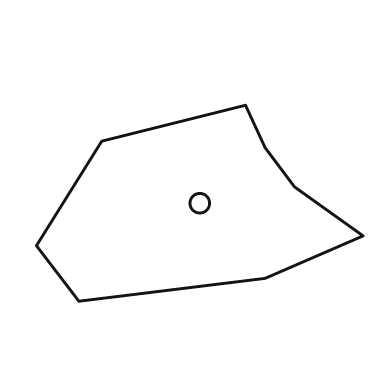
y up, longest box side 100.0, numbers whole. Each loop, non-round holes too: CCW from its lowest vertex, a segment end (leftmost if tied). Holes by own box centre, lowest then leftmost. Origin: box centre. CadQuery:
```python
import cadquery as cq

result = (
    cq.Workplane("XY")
    .moveTo(-37.0, -30.0)
    .lineTo(20.0, -23.0)
    .lineTo(50.0, -10.0)
    .lineTo(29.0, 5.0)
    .lineTo(20.0, 17.0)
    .lineTo(14.0, 30.0)
    .lineTo(-30.0, 19.0)
    .lineTo(-50.0, -13.0)
    .close()
    .moveTo(0.0, 0.0)
    .circle(3.0)
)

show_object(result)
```